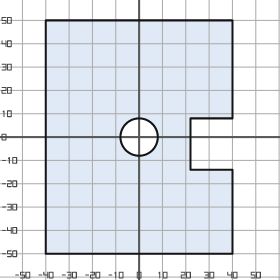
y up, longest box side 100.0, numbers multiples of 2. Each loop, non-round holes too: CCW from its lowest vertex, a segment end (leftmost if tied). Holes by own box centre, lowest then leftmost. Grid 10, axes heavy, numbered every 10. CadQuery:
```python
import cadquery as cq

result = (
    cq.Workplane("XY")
    .moveTo(-40.0, -50.0)
    .lineTo(40.0, -50.0)
    .lineTo(40.0, -14.0)
    .lineTo(22.0, -14.0)
    .lineTo(22.0, 8.0)
    .lineTo(40.0, 8.0)
    .lineTo(40.0, 50.0)
    .lineTo(-40.0, 50.0)
    .close()
    .moveTo(0.0, 0.0)
    .circle(8.0)
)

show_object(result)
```